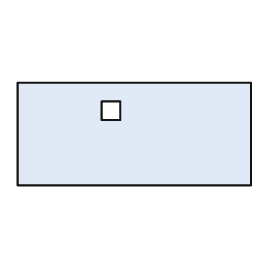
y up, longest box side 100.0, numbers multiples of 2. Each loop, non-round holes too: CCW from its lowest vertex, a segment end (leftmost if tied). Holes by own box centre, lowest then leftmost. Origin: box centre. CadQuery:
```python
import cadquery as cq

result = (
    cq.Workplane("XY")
    .moveTo(-50.0, -22.0)
    .lineTo(50.0, -22.0)
    .lineTo(50.0, 22.0)
    .lineTo(-50.0, 22.0)
    .close()
    .moveTo(-14.0, 6.0)
    .lineTo(-6.0, 6.0)
    .lineTo(-6.0, 14.0)
    .lineTo(-14.0, 14.0)
    .close()
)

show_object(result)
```